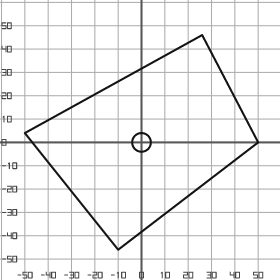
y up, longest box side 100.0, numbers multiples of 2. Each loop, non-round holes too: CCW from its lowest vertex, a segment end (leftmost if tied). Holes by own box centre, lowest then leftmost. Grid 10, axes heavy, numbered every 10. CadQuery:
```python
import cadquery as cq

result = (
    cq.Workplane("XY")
    .moveTo(-10.0, -46.0)
    .lineTo(50.0, 0.0)
    .lineTo(26.0, 46.0)
    .lineTo(-50.0, 4.0)
    .close()
    .moveTo(0.0, 0.0)
    .circle(4.0)
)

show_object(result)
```